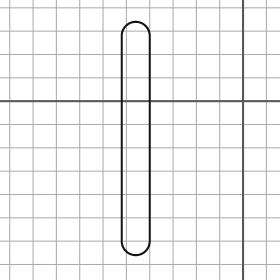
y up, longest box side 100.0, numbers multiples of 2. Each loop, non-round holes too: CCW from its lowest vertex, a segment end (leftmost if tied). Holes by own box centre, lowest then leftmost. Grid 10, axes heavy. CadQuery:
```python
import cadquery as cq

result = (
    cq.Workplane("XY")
    .moveTo(-52.0, -60.0)
    .threePointArc((-46.0, -66.0), (-40.0, -60.0))
    .lineTo(-40.0, 28.0)
    .threePointArc((-46.0, 34.0), (-52.0, 28.0))
    .close()
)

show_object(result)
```